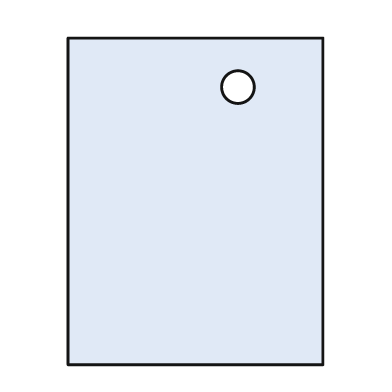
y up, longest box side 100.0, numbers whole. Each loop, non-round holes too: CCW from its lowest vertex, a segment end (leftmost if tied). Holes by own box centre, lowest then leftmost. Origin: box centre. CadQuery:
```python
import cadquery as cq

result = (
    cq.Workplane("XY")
    .moveTo(-39.0, -50.0)
    .lineTo(39.0, -50.0)
    .lineTo(39.0, 50.0)
    .lineTo(-39.0, 50.0)
    .close()
    .moveTo(13.0, 35.0)
    .circle(5.0)
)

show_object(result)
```